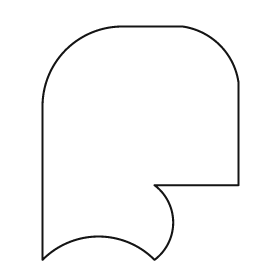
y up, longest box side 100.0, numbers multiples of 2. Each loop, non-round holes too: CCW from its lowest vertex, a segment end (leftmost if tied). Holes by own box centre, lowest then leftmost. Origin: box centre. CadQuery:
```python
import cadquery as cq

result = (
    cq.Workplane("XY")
    .moveTo(-42.0, -50.0)
    .threePointArc((-18.0, -40.0), (6.0, -50.0))
    .threePointArc((14.0, -34.0), (6.0, -18.0))
    .lineTo(42.0, -18.0)
    .lineTo(42.0, 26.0)
    .threePointArc((34.0, 42.0), (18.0, 50.0))
    .lineTo(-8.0, 50.0)
    .threePointArc((-32.0, 40.0), (-42.0, 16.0))
    .close()
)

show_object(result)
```